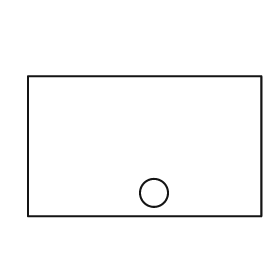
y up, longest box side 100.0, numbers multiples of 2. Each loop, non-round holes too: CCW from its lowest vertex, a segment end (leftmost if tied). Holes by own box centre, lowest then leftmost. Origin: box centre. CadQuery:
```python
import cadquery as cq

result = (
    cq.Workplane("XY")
    .moveTo(-50.0, -30.0)
    .lineTo(50.0, -30.0)
    .lineTo(50.0, 30.0)
    .lineTo(-50.0, 30.0)
    .close()
    .moveTo(4.0, -20.0)
    .circle(6.0)
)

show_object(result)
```